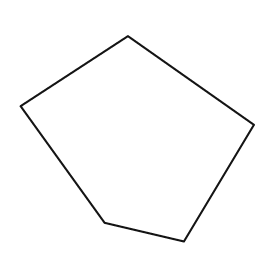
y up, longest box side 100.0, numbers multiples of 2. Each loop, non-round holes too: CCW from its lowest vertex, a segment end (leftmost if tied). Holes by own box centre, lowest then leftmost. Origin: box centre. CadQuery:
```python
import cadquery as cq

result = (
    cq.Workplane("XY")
    .moveTo(20.0, -44.0)
    .lineTo(50.0, 6.0)
    .lineTo(-4.0, 44.0)
    .lineTo(-50.0, 14.0)
    .lineTo(-14.0, -36.0)
    .close()
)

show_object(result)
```